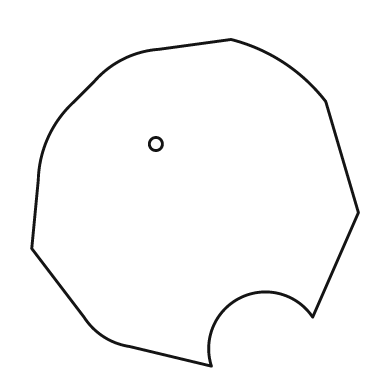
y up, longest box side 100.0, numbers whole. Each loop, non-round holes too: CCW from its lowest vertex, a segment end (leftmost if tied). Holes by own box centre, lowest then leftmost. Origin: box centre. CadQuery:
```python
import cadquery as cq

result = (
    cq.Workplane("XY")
    .moveTo(5.0, -50.0)
    .threePointArc((14.0, -29.0), (36.0, -35.0))
    .lineTo(50.0, -3.0)
    .lineTo(40.0, 31.0)
    .threePointArc((27.0, 43.0), (11.0, 50.0))
    .lineTo(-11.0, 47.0)
    .threePointArc((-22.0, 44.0), (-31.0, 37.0))
    .lineTo(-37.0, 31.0)
    .threePointArc((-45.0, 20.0), (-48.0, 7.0))
    .lineTo(-50.0, -14.0)
    .lineTo(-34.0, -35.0)
    .threePointArc((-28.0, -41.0), (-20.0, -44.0))
    .close()
    .moveTo(-12.0, 18.0)
    .circle(2.0)
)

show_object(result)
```